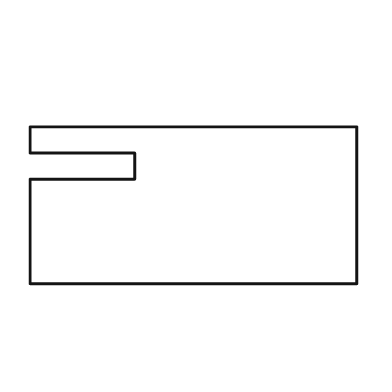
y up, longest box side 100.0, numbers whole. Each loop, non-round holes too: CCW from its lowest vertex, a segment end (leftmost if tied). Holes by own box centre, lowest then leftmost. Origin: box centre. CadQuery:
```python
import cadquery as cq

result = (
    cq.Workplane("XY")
    .moveTo(-50.0, -24.0)
    .lineTo(50.0, -24.0)
    .lineTo(50.0, 24.0)
    .lineTo(-50.0, 24.0)
    .lineTo(-50.0, 16.0)
    .lineTo(-18.0, 16.0)
    .lineTo(-18.0, 8.0)
    .lineTo(-50.0, 8.0)
    .close()
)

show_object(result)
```